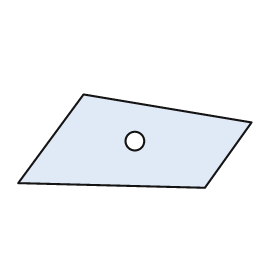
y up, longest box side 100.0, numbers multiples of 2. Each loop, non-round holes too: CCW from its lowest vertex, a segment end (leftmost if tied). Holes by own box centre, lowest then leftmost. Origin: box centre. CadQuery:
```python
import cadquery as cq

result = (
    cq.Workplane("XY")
    .moveTo(30.0, -20.0)
    .lineTo(50.0, 8.0)
    .lineTo(-22.0, 20.0)
    .lineTo(-50.0, -18.0)
    .close()
    .moveTo(0.0, 0.0)
    .circle(4.0)
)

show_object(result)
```